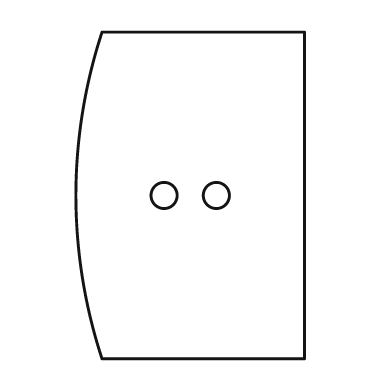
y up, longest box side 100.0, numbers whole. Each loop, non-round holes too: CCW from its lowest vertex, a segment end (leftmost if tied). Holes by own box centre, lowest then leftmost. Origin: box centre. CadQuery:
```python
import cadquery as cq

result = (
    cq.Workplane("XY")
    .moveTo(-27.0, -50.0)
    .lineTo(35.0, -50.0)
    .lineTo(35.0, 50.0)
    .lineTo(-27.0, 50.0)
    .threePointArc((-35.0, 0.0), (-27.0, -50.0))
    .close()
    .moveTo(-8.0, 0.0)
    .circle(4.0)
    .moveTo(8.0, 0.0)
    .circle(4.0)
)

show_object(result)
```